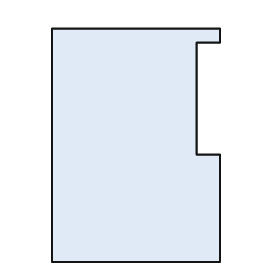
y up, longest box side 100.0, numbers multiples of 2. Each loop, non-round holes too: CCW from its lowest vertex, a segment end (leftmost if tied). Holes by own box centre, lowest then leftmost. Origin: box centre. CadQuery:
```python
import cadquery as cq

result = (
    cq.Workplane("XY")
    .moveTo(-36.0, -50.0)
    .lineTo(36.0, -50.0)
    .lineTo(36.0, -4.0)
    .lineTo(26.0, -4.0)
    .lineTo(26.0, 44.0)
    .lineTo(36.0, 44.0)
    .lineTo(36.0, 50.0)
    .lineTo(-36.0, 50.0)
    .close()
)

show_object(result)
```